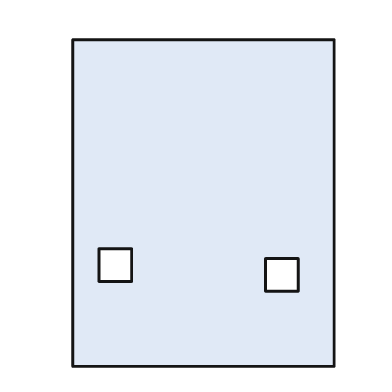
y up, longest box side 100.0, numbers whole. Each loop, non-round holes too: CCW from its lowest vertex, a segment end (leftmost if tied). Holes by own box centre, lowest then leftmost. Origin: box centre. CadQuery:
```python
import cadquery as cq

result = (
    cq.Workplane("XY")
    .moveTo(-40.0, -50.0)
    .lineTo(40.0, -50.0)
    .lineTo(40.0, 50.0)
    .lineTo(-40.0, 50.0)
    .close()
    .moveTo(19.0, -27.0)
    .lineTo(29.0, -27.0)
    .lineTo(29.0, -17.0)
    .lineTo(19.0, -17.0)
    .close()
    .moveTo(-32.0, -24.0)
    .lineTo(-22.0, -24.0)
    .lineTo(-22.0, -14.0)
    .lineTo(-32.0, -14.0)
    .close()
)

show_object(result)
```